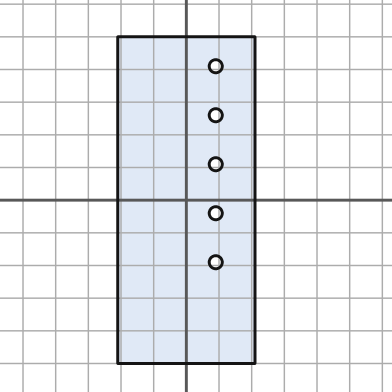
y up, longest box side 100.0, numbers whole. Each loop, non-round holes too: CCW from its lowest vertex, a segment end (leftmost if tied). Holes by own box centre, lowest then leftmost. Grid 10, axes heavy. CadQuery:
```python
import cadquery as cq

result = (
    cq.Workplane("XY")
    .moveTo(-21.0, -50.0)
    .lineTo(21.0, -50.0)
    .lineTo(21.0, 50.0)
    .lineTo(-21.0, 50.0)
    .close()
    .moveTo(9.0, -19.0)
    .circle(2.0)
    .moveTo(9.0, -4.0)
    .circle(2.0)
    .moveTo(9.0, 11.0)
    .circle(2.0)
    .moveTo(9.0, 26.0)
    .circle(2.0)
    .moveTo(9.0, 41.0)
    .circle(2.0)
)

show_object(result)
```